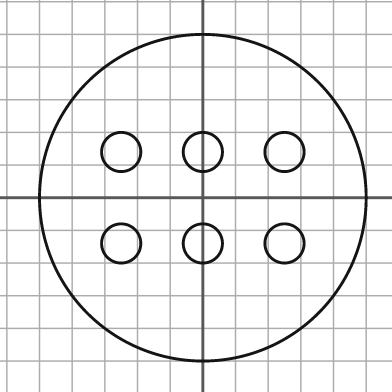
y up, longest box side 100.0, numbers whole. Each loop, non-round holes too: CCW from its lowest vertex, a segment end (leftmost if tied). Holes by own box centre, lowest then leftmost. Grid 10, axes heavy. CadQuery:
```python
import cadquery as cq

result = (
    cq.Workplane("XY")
    .moveTo(0.0, 0.0)
    .circle(50.0)
    .moveTo(-25.0, -14.0)
    .circle(6.0)
    .moveTo(0.0, -14.0)
    .circle(6.0)
    .moveTo(25.0, -14.0)
    .circle(6.0)
    .moveTo(-25.0, 14.0)
    .circle(6.0)
    .moveTo(0.0, 14.0)
    .circle(6.0)
    .moveTo(25.0, 14.0)
    .circle(6.0)
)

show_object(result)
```